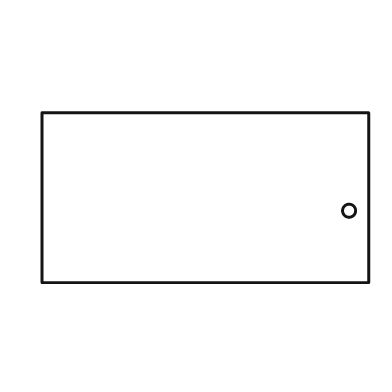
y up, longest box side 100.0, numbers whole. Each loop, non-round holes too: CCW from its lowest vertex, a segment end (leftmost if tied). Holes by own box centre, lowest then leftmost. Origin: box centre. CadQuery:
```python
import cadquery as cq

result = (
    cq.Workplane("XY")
    .moveTo(-50.0, -26.0)
    .lineTo(50.0, -26.0)
    .lineTo(50.0, 26.0)
    .lineTo(-50.0, 26.0)
    .close()
    .moveTo(44.0, -4.0)
    .circle(2.0)
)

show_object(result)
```